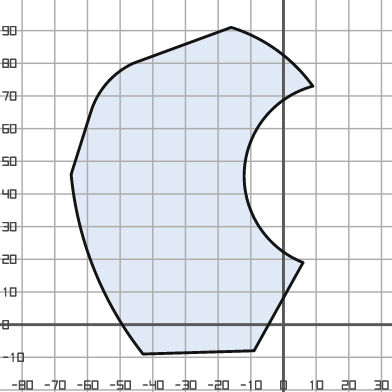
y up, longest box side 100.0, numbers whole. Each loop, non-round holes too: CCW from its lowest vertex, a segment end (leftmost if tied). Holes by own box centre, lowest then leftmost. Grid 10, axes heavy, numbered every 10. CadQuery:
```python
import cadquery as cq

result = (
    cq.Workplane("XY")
    .moveTo(-43.0, -9.0)
    .lineTo(-9.0, -8.0)
    .lineTo(6.0, 19.0)
    .threePointArc((-12.0, 47.0), (9.0, 73.0))
    .threePointArc((-2.0, 84.0), (-16.0, 91.0))
    .lineTo(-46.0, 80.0)
    .threePointArc((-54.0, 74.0), (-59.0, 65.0))
    .lineTo(-65.0, 46.0)
    .threePointArc((-58.0, 17.0), (-43.0, -9.0))
    .close()
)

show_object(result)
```